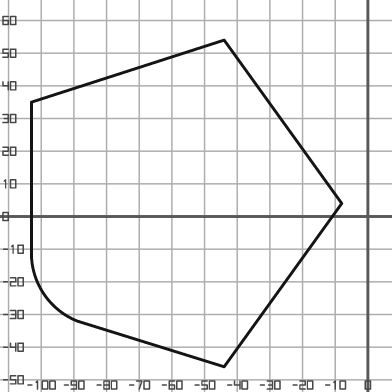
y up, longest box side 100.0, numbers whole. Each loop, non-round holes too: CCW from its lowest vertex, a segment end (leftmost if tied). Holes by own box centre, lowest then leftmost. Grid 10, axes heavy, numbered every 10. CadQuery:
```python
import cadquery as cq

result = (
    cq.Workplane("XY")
    .moveTo(-44.0, -46.0)
    .lineTo(-8.0, 4.0)
    .lineTo(-44.0, 54.0)
    .lineTo(-103.0, 35.0)
    .lineTo(-103.0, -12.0)
    .threePointArc((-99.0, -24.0), (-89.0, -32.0))
    .close()
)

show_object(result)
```